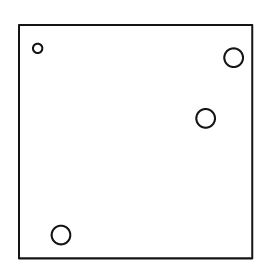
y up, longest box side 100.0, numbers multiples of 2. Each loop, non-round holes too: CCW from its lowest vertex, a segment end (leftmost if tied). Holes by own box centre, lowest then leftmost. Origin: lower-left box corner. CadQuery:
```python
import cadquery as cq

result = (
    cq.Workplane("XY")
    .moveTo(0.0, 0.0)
    .lineTo(100.0, 0.0)
    .lineTo(100.0, 100.0)
    .lineTo(0.0, 100.0)
    .close()
    .moveTo(18.0, 10.0)
    .circle(4.0)
    .moveTo(80.0, 60.0)
    .circle(4.0)
    .moveTo(92.0, 86.0)
    .circle(4.0)
    .moveTo(8.0, 90.0)
    .circle(2.0)
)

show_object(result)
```